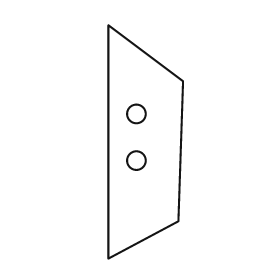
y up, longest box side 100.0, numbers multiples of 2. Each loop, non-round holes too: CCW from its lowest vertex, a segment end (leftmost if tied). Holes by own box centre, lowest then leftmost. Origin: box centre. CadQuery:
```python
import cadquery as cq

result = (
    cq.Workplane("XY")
    .moveTo(-16.0, -50.0)
    .lineTo(14.0, -34.0)
    .lineTo(16.0, 26.0)
    .lineTo(-16.0, 50.0)
    .close()
    .moveTo(-4.0, -8.0)
    .circle(4.0)
    .moveTo(-4.0, 12.0)
    .circle(4.0)
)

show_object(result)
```